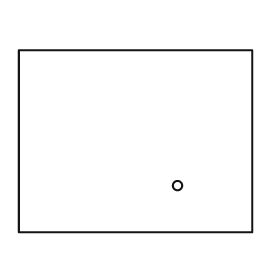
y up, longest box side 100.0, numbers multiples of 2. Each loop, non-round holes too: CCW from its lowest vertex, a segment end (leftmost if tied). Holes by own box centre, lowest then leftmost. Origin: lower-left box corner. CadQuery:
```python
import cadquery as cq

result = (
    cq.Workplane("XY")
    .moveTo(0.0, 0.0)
    .lineTo(100.0, 0.0)
    .lineTo(100.0, 78.0)
    .lineTo(0.0, 78.0)
    .close()
    .moveTo(68.0, 20.0)
    .circle(2.0)
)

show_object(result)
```